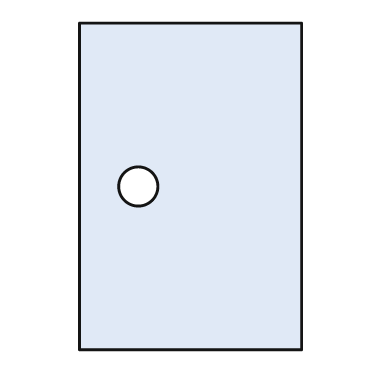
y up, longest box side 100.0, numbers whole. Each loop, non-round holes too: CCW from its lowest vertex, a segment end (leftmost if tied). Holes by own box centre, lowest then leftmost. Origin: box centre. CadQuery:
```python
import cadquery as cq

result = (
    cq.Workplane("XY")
    .moveTo(-34.0, -50.0)
    .lineTo(34.0, -50.0)
    .lineTo(34.0, 50.0)
    .lineTo(-34.0, 50.0)
    .close()
    .moveTo(-16.0, 0.0)
    .circle(6.0)
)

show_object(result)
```